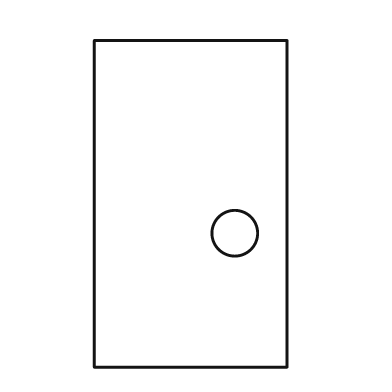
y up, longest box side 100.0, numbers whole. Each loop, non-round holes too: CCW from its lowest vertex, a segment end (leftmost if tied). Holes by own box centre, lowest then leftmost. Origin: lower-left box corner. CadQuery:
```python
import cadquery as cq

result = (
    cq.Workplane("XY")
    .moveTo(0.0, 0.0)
    .lineTo(59.0, 0.0)
    .lineTo(59.0, 100.0)
    .lineTo(0.0, 100.0)
    .close()
    .moveTo(43.0, 41.0)
    .circle(7.0)
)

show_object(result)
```